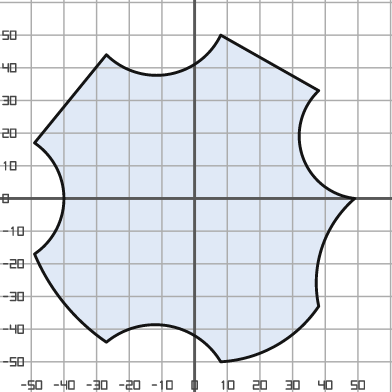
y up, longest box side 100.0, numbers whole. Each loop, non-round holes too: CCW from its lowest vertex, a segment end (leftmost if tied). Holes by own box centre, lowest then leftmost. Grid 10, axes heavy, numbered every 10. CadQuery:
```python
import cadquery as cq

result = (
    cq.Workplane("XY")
    .moveTo(8.0, -50.0)
    .threePointArc((25.0, -45.0), (38.0, -33.0))
    .threePointArc((39.0, -15.0), (49.0, 0.0))
    .threePointArc((33.0, 13.0), (38.0, 33.0))
    .lineTo(8.0, 50.0)
    .threePointArc((-8.0, 38.0), (-27.0, 44.0))
    .lineTo(-49.0, 17.0)
    .threePointArc((-40.0, 0.0), (-49.0, -17.0))
    .threePointArc((-40.0, -32.0), (-27.0, -44.0))
    .threePointArc((-8.0, -39.0), (8.0, -50.0))
    .close()
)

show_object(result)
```